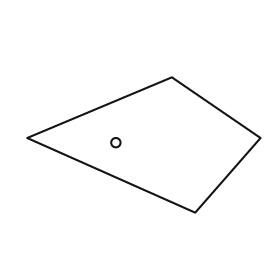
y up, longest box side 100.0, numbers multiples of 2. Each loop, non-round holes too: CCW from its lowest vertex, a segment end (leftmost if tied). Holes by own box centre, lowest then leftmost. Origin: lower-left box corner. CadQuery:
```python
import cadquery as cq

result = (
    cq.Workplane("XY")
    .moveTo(72.0, 0.0)
    .lineTo(100.0, 32.0)
    .lineTo(62.0, 58.0)
    .lineTo(0.0, 32.0)
    .close()
    .moveTo(38.0, 30.0)
    .circle(2.0)
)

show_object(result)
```